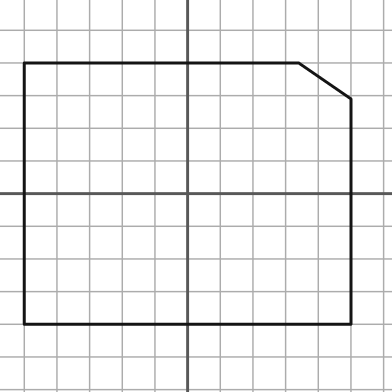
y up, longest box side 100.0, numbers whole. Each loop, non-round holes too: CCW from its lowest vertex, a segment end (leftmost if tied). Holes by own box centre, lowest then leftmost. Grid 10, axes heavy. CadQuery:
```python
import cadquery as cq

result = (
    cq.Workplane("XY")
    .moveTo(-50.0, -40.0)
    .lineTo(50.0, -40.0)
    .lineTo(50.0, 29.0)
    .lineTo(34.0, 40.0)
    .lineTo(-50.0, 40.0)
    .close()
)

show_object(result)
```